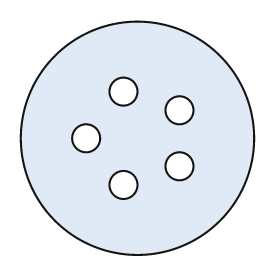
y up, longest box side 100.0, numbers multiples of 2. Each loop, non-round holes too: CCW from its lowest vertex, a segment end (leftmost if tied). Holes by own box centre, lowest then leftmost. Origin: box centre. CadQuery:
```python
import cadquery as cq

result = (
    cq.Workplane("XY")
    .moveTo(0.0, 0.0)
    .circle(50.0)
    .moveTo(-6.0, -20.0)
    .circle(6.0)
    .moveTo(18.0, -12.0)
    .circle(6.0)
    .moveTo(-22.0, 0.0)
    .circle(6.0)
    .moveTo(18.0, 12.0)
    .circle(6.0)
    .moveTo(-6.0, 20.0)
    .circle(6.0)
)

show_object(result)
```